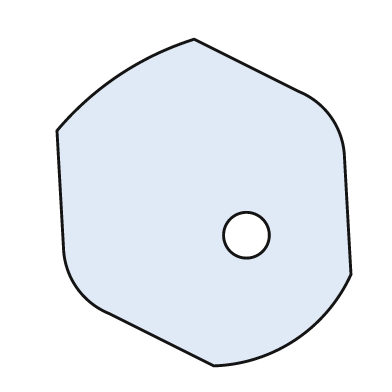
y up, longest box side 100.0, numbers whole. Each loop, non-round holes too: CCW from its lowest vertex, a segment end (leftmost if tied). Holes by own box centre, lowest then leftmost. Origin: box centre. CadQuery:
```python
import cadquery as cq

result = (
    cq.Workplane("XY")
    .moveTo(3.0, -50.0)
    .threePointArc((28.0, -42.0), (45.0, -22.0))
    .lineTo(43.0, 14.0)
    .threePointArc((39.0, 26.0), (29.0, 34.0))
    .lineTo(-3.0, 50.0)
    .threePointArc((-26.0, 39.0), (-45.0, 22.0))
    .lineTo(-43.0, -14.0)
    .threePointArc((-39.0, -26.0), (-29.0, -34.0))
    .close()
    .moveTo(13.0, -10.0)
    .circle(7.0)
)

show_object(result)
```